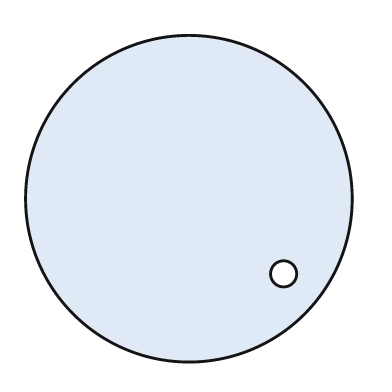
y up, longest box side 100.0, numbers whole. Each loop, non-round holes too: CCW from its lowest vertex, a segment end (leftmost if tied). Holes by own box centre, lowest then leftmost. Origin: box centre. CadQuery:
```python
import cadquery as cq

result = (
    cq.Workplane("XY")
    .moveTo(0.0, 0.0)
    .circle(50.0)
    .moveTo(29.0, -23.0)
    .circle(4.0)
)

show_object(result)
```